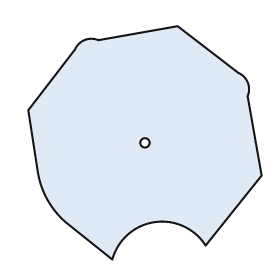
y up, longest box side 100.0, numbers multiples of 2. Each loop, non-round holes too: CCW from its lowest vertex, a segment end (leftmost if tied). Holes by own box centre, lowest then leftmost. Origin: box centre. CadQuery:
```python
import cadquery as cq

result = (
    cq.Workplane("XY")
    .moveTo(-14.0, -50.0)
    .threePointArc((4.0, -34.0), (26.0, -44.0))
    .lineTo(50.0, -14.0)
    .lineTo(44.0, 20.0)
    .threePointArc((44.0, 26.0), (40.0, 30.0))
    .lineTo(14.0, 50.0)
    .lineTo(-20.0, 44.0)
    .threePointArc((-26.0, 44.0), (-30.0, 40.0))
    .lineTo(-50.0, 14.0)
    .lineTo(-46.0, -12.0)
    .threePointArc((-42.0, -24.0), (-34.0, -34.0))
    .close()
    .moveTo(0.0, 0.0)
    .circle(2.0)
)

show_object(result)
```